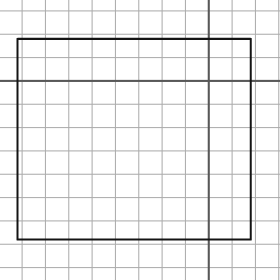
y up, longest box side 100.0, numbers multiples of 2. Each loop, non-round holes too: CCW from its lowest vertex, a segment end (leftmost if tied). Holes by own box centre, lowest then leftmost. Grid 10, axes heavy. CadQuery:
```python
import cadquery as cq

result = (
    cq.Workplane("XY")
    .moveTo(-82.0, -68.0)
    .lineTo(18.0, -68.0)
    .lineTo(18.0, 18.0)
    .lineTo(-82.0, 18.0)
    .close()
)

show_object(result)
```